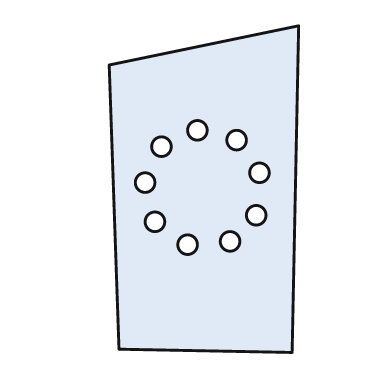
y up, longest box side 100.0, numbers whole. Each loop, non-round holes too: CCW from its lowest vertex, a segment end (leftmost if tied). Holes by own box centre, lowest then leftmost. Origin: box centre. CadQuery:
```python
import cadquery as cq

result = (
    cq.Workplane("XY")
    .moveTo(27.0, -50.0)
    .lineTo(29.0, 50.0)
    .lineTo(-29.0, 38.0)
    .lineTo(-26.0, -49.0)
    .close()
    .moveTo(-5.0, -17.0)
    .circle(3.0)
    .moveTo(8.0, -16.0)
    .circle(3.0)
    .moveTo(-15.0, -10.0)
    .circle(3.0)
    .moveTo(16.0, -8.0)
    .circle(3.0)
    .moveTo(-18.0, 2.0)
    .circle(3.0)
    .moveTo(17.0, 5.0)
    .circle(3.0)
    .moveTo(-13.0, 13.0)
    .circle(3.0)
    .moveTo(10.0, 15.0)
    .circle(3.0)
    .moveTo(-2.0, 18.0)
    .circle(3.0)
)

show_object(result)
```